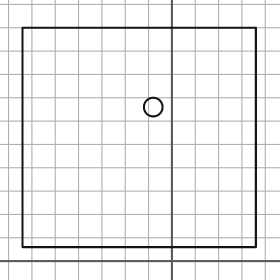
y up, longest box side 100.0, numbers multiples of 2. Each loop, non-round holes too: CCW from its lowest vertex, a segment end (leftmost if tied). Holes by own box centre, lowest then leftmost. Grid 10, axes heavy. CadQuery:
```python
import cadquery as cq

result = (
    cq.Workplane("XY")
    .moveTo(-64.0, 6.0)
    .lineTo(36.0, 6.0)
    .lineTo(36.0, 100.0)
    .lineTo(-64.0, 100.0)
    .close()
    .moveTo(-8.0, 66.0)
    .circle(4.0)
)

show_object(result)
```